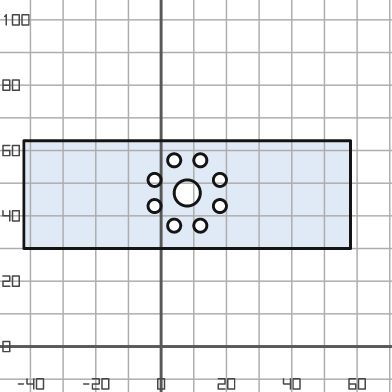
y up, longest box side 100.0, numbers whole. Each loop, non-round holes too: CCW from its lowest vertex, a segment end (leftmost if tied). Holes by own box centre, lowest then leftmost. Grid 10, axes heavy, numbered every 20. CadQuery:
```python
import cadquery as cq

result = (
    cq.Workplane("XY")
    .moveTo(-42.0, 30.0)
    .lineTo(58.0, 30.0)
    .lineTo(58.0, 63.0)
    .lineTo(-42.0, 63.0)
    .close()
    .moveTo(4.0, 37.0)
    .circle(2.0)
    .moveTo(12.0, 37.0)
    .circle(2.0)
    .moveTo(-2.0, 43.0)
    .circle(2.0)
    .moveTo(18.0, 43.0)
    .circle(2.0)
    .moveTo(8.0, 47.0)
    .circle(4.0)
    .moveTo(-2.0, 51.0)
    .circle(2.0)
    .moveTo(18.0, 51.0)
    .circle(2.0)
    .moveTo(4.0, 57.0)
    .circle(2.0)
    .moveTo(12.0, 57.0)
    .circle(2.0)
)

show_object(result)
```